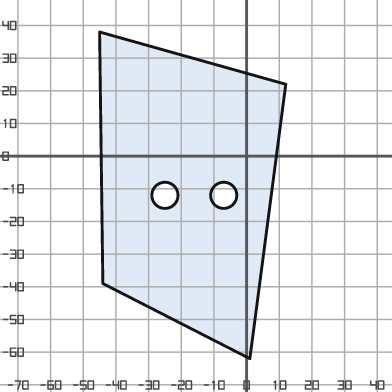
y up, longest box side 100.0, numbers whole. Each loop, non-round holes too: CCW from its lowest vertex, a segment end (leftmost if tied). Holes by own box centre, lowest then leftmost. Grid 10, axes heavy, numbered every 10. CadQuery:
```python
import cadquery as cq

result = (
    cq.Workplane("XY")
    .moveTo(1.0, -62.0)
    .lineTo(12.0, 22.0)
    .lineTo(-45.0, 38.0)
    .lineTo(-44.0, -39.0)
    .close()
    .moveTo(-25.0, -12.0)
    .circle(4.0)
    .moveTo(-7.0, -12.0)
    .circle(4.0)
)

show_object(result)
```